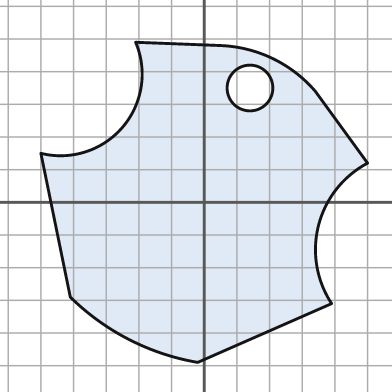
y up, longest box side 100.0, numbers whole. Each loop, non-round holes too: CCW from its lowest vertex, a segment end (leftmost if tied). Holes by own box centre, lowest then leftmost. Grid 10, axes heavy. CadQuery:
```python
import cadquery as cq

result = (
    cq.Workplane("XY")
    .moveTo(-2.0, -49.0)
    .lineTo(39.0, -31.0)
    .threePointArc((35.0, -7.0), (50.0, 12.0))
    .lineTo(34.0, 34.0)
    .threePointArc((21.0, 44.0), (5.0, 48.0))
    .lineTo(-21.0, 49.0)
    .threePointArc((-25.0, 23.0), (-50.0, 15.0))
    .lineTo(-41.0, -29.0)
    .threePointArc((-23.0, -42.0), (-2.0, -49.0))
    .close()
    .moveTo(14.0, 35.0)
    .circle(7.0)
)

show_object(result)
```